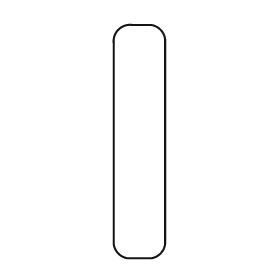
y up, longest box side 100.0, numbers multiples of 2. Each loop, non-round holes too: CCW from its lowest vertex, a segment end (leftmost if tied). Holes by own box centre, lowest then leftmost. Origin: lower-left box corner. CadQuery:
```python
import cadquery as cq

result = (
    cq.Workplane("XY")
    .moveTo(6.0, 0.0)
    .lineTo(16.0, 0.0)
    .threePointArc((20.0, 2.0), (22.0, 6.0))
    .lineTo(22.0, 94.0)
    .threePointArc((20.0, 98.0), (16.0, 100.0))
    .lineTo(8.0, 100.0)
    .threePointArc((2.0, 98.0), (0.0, 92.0))
    .lineTo(0.0, 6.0)
    .threePointArc((2.0, 2.0), (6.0, 0.0))
    .close()
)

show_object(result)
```